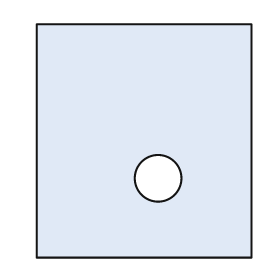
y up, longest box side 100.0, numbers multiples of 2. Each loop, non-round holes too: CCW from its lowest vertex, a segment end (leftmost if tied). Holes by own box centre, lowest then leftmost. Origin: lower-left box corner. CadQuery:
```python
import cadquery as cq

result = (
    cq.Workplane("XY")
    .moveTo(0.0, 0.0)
    .lineTo(92.0, 0.0)
    .lineTo(92.0, 100.0)
    .lineTo(0.0, 100.0)
    .close()
    .moveTo(52.0, 34.0)
    .circle(10.0)
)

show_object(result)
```